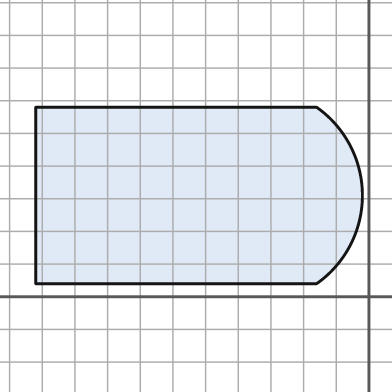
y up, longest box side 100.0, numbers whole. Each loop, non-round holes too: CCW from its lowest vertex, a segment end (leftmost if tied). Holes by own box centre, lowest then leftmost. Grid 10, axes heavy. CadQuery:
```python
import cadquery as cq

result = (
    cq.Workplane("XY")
    .moveTo(-102.0, 4.0)
    .lineTo(-16.0, 4.0)
    .threePointArc((-2.0, 31.0), (-16.0, 58.0))
    .lineTo(-102.0, 58.0)
    .close()
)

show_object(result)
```